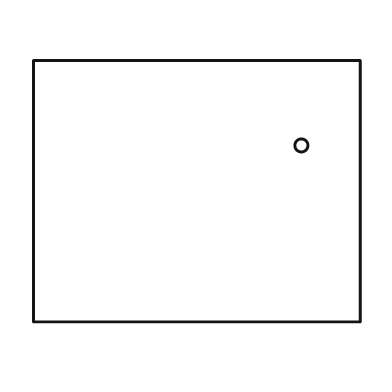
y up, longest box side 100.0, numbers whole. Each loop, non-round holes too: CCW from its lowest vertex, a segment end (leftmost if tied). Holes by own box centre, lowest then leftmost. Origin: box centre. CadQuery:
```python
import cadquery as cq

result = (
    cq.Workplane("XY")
    .moveTo(-50.0, -40.0)
    .lineTo(50.0, -40.0)
    .lineTo(50.0, 40.0)
    .lineTo(-50.0, 40.0)
    .close()
    .moveTo(32.0, 14.0)
    .circle(2.0)
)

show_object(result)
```